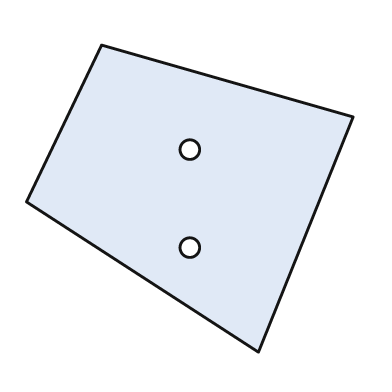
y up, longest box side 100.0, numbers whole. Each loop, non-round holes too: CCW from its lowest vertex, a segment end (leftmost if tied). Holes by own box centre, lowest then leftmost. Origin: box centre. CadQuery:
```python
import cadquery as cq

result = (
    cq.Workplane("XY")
    .moveTo(21.0, -47.0)
    .lineTo(50.0, 25.0)
    .lineTo(-27.0, 47.0)
    .lineTo(-50.0, -1.0)
    .close()
    .moveTo(0.0, -15.0)
    .circle(3.0)
    .moveTo(0.0, 15.0)
    .circle(3.0)
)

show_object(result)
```